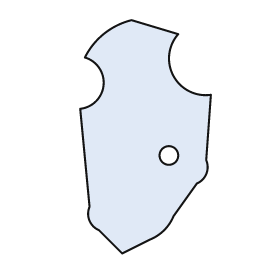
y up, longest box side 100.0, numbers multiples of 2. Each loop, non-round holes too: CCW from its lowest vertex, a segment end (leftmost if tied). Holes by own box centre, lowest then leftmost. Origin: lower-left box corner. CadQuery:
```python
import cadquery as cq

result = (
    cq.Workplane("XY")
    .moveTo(18.0, 0.0)
    .lineTo(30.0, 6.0)
    .threePointArc((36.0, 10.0), (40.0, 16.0))
    .lineTo(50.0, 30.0)
    .threePointArc((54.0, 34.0), (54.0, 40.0))
    .lineTo(56.0, 68.0)
    .threePointArc((40.0, 76.0), (42.0, 94.0))
    .lineTo(22.0, 100.0)
    .threePointArc((10.0, 94.0), (2.0, 84.0))
    .threePointArc((10.0, 72.0), (0.0, 62.0))
    .lineTo(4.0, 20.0)
    .threePointArc((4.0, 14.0), (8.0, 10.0))
    .close()
    .moveTo(38.0, 42.0)
    .circle(4.0)
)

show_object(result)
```